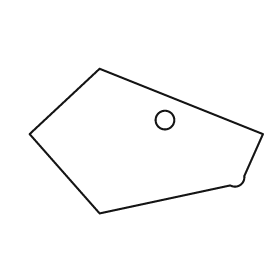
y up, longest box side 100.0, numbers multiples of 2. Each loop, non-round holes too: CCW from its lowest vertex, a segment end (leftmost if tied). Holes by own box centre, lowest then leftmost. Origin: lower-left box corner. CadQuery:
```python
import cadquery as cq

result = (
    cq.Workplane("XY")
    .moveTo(30.0, 0.0)
    .lineTo(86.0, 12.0)
    .threePointArc((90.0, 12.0), (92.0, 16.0))
    .lineTo(100.0, 34.0)
    .lineTo(30.0, 62.0)
    .lineTo(0.0, 34.0)
    .close()
    .moveTo(58.0, 40.0)
    .circle(4.0)
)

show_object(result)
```